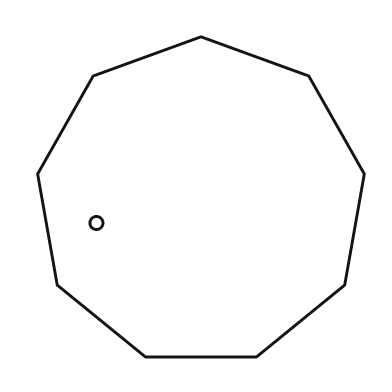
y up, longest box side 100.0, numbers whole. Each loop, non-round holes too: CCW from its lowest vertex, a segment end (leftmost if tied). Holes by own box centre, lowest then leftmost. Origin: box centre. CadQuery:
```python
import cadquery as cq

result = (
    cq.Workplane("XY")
    .moveTo(-17.0, -49.0)
    .lineTo(17.0, -49.0)
    .lineTo(44.0, -27.0)
    .lineTo(50.0, 7.0)
    .lineTo(33.0, 37.0)
    .lineTo(0.0, 49.0)
    .lineTo(-33.0, 37.0)
    .lineTo(-50.0, 7.0)
    .lineTo(-44.0, -27.0)
    .close()
    .moveTo(-32.0, -8.0)
    .circle(2.0)
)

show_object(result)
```